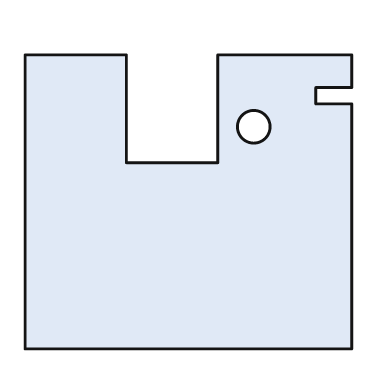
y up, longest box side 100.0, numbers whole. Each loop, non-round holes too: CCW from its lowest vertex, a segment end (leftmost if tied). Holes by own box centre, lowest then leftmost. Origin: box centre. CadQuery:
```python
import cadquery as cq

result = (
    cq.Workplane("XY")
    .moveTo(-50.0, -45.0)
    .lineTo(50.0, -45.0)
    .lineTo(50.0, 30.0)
    .lineTo(39.0, 30.0)
    .lineTo(39.0, 35.0)
    .lineTo(50.0, 35.0)
    .lineTo(50.0, 45.0)
    .lineTo(9.0, 45.0)
    .lineTo(9.0, 12.0)
    .lineTo(-19.0, 12.0)
    .lineTo(-19.0, 45.0)
    .lineTo(-50.0, 45.0)
    .close()
    .moveTo(20.0, 23.0)
    .circle(5.0)
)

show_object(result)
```